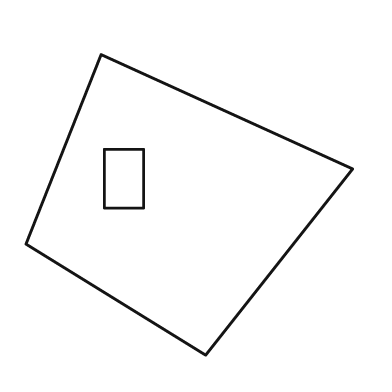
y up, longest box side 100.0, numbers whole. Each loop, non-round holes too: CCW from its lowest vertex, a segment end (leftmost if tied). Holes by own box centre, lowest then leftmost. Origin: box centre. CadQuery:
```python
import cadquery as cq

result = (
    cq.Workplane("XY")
    .moveTo(5.0, -46.0)
    .lineTo(50.0, 11.0)
    .lineTo(-27.0, 46.0)
    .lineTo(-50.0, -12.0)
    .close()
    .moveTo(-26.0, -1.0)
    .lineTo(-14.0, -1.0)
    .lineTo(-14.0, 17.0)
    .lineTo(-26.0, 17.0)
    .close()
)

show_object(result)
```